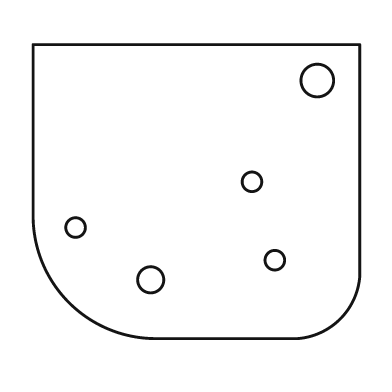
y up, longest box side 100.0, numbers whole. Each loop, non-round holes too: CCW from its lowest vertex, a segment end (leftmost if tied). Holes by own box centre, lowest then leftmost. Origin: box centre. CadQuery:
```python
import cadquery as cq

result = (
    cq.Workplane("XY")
    .moveTo(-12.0, -45.0)
    .lineTo(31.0, -45.0)
    .threePointArc((44.0, -39.0), (50.0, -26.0))
    .lineTo(50.0, 45.0)
    .lineTo(-50.0, 45.0)
    .lineTo(-50.0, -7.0)
    .threePointArc((-39.0, -34.0), (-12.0, -45.0))
    .close()
    .moveTo(-14.0, -27.0)
    .circle(4.0)
    .moveTo(24.0, -21.0)
    .circle(3.0)
    .moveTo(-37.0, -11.0)
    .circle(3.0)
    .moveTo(17.0, 3.0)
    .circle(3.0)
    .moveTo(37.0, 34.0)
    .circle(5.0)
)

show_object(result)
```